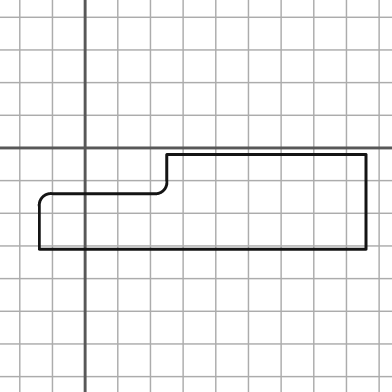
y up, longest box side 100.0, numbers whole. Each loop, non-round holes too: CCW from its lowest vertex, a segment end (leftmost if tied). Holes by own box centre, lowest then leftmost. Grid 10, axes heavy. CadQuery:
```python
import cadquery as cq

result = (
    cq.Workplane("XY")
    .moveTo(-14.0, -31.0)
    .lineTo(86.0, -31.0)
    .lineTo(86.0, -2.0)
    .lineTo(25.0, -2.0)
    .lineTo(25.0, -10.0)
    .threePointArc((24.0, -13.0), (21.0, -14.0))
    .lineTo(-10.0, -14.0)
    .threePointArc((-13.0, -15.0), (-14.0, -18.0))
    .close()
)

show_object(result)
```